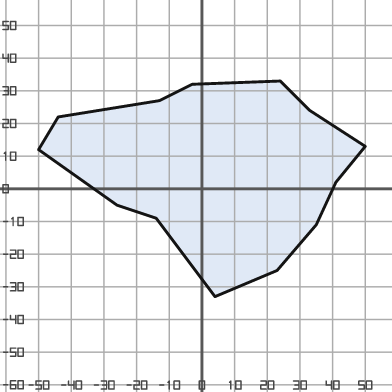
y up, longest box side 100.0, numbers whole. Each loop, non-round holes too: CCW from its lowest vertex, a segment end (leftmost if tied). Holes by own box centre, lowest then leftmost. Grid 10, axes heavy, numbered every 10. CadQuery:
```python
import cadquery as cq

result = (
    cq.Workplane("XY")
    .moveTo(4.0, -33.0)
    .lineTo(23.0, -25.0)
    .lineTo(35.0, -11.0)
    .lineTo(41.0, 2.0)
    .lineTo(50.0, 13.0)
    .lineTo(33.0, 24.0)
    .lineTo(24.0, 33.0)
    .lineTo(-3.0, 32.0)
    .lineTo(-13.0, 27.0)
    .lineTo(-44.0, 22.0)
    .lineTo(-50.0, 12.0)
    .lineTo(-26.0, -5.0)
    .lineTo(-14.0, -9.0)
    .close()
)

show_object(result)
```